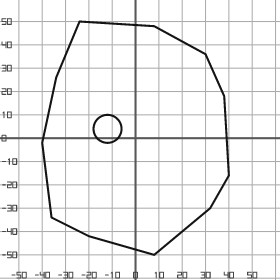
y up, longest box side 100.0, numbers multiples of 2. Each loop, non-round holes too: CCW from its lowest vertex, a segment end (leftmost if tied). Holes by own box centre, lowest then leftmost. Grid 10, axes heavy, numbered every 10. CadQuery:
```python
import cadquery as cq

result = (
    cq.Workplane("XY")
    .moveTo(8.0, -50.0)
    .lineTo(32.0, -30.0)
    .lineTo(40.0, -16.0)
    .lineTo(38.0, 18.0)
    .lineTo(30.0, 36.0)
    .lineTo(8.0, 48.0)
    .lineTo(-24.0, 50.0)
    .lineTo(-34.0, 26.0)
    .lineTo(-40.0, -2.0)
    .lineTo(-36.0, -34.0)
    .lineTo(-20.0, -42.0)
    .close()
    .moveTo(-12.0, 4.0)
    .circle(6.0)
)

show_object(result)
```